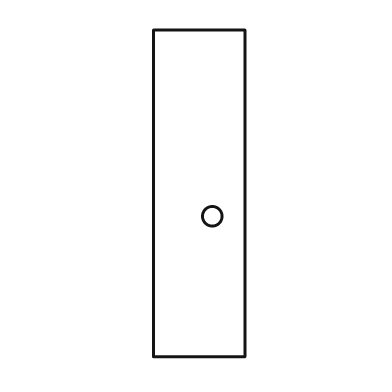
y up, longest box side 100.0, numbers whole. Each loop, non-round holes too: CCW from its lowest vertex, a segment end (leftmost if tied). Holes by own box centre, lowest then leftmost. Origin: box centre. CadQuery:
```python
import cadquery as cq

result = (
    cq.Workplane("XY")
    .moveTo(-14.0, -50.0)
    .lineTo(14.0, -50.0)
    .lineTo(14.0, 50.0)
    .lineTo(-14.0, 50.0)
    .close()
    .moveTo(4.0, -7.0)
    .circle(3.0)
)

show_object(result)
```